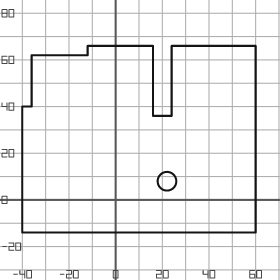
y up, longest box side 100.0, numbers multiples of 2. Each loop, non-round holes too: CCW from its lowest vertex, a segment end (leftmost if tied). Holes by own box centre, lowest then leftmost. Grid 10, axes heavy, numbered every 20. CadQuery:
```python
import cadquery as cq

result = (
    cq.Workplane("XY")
    .moveTo(-40.0, -14.0)
    .lineTo(60.0, -14.0)
    .lineTo(60.0, 66.0)
    .lineTo(24.0, 66.0)
    .lineTo(24.0, 36.0)
    .lineTo(16.0, 36.0)
    .lineTo(16.0, 66.0)
    .lineTo(-12.0, 66.0)
    .lineTo(-12.0, 62.0)
    .lineTo(-36.0, 62.0)
    .lineTo(-36.0, 40.0)
    .lineTo(-40.0, 40.0)
    .close()
    .moveTo(22.0, 8.0)
    .circle(4.0)
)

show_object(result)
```